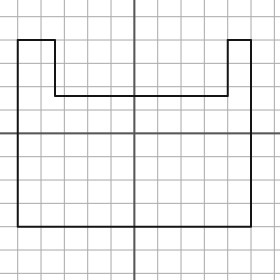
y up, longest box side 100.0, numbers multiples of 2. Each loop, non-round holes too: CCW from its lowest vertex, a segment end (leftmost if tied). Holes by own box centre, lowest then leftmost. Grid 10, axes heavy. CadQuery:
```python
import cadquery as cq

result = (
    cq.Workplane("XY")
    .moveTo(-50.0, -40.0)
    .lineTo(50.0, -40.0)
    .lineTo(50.0, 40.0)
    .lineTo(40.0, 40.0)
    .lineTo(40.0, 16.0)
    .lineTo(-34.0, 16.0)
    .lineTo(-34.0, 40.0)
    .lineTo(-50.0, 40.0)
    .close()
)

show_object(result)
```